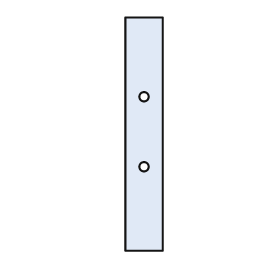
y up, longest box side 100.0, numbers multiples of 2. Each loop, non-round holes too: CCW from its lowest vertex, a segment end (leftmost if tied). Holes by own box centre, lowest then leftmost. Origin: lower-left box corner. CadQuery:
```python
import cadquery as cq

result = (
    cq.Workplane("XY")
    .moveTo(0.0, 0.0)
    .lineTo(16.0, 0.0)
    .lineTo(16.0, 100.0)
    .lineTo(0.0, 100.0)
    .close()
    .moveTo(8.0, 36.0)
    .circle(2.0)
    .moveTo(8.0, 66.0)
    .circle(2.0)
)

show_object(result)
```